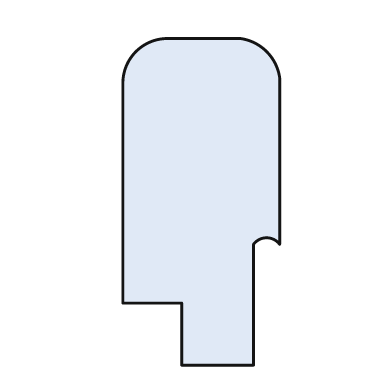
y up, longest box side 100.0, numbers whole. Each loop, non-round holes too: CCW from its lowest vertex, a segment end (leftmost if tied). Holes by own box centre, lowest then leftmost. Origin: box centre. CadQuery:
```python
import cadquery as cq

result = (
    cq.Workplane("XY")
    .moveTo(-6.0, -50.0)
    .lineTo(16.0, -50.0)
    .lineTo(16.0, -13.0)
    .threePointArc((20.0, -11.0), (24.0, -13.0))
    .lineTo(24.0, 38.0)
    .threePointArc((20.0, 46.0), (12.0, 50.0))
    .lineTo(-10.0, 50.0)
    .threePointArc((-20.0, 46.0), (-24.0, 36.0))
    .lineTo(-24.0, -31.0)
    .lineTo(-6.0, -31.0)
    .close()
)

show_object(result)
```